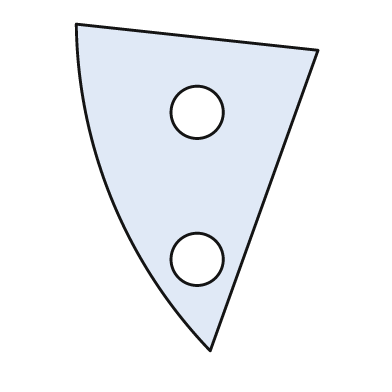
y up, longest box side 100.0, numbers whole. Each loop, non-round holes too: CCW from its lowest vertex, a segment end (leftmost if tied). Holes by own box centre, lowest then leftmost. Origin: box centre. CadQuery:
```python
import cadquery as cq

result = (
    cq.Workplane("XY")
    .moveTo(4.0, -50.0)
    .lineTo(37.0, 42.0)
    .lineTo(-37.0, 50.0)
    .threePointArc((-26.0, -4.0), (4.0, -50.0))
    .close()
    .moveTo(0.0, -22.0)
    .circle(8.0)
    .moveTo(0.0, 23.0)
    .circle(8.0)
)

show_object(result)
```